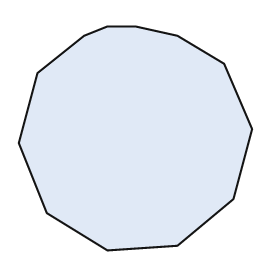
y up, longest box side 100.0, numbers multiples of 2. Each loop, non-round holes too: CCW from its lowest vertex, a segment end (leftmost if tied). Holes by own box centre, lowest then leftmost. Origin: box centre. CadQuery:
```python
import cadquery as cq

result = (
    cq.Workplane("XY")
    .moveTo(-12.0, -48.0)
    .lineTo(18.0, -46.0)
    .lineTo(42.0, -26.0)
    .lineTo(50.0, 4.0)
    .lineTo(38.0, 32.0)
    .lineTo(18.0, 44.0)
    .lineTo(0.0, 48.0)
    .lineTo(-12.0, 48.0)
    .lineTo(-22.0, 44.0)
    .lineTo(-42.0, 28.0)
    .lineTo(-50.0, -2.0)
    .lineTo(-38.0, -32.0)
    .close()
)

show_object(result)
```